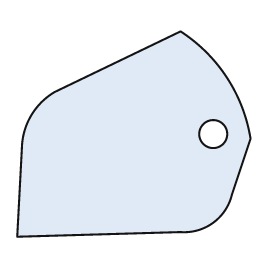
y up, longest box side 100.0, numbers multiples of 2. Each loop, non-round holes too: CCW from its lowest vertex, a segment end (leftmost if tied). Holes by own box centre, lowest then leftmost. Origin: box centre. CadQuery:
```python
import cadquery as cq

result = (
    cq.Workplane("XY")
    .moveTo(-50.0, -44.0)
    .lineTo(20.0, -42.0)
    .threePointArc((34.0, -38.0), (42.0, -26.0))
    .lineTo(50.0, -2.0)
    .threePointArc((40.0, 24.0), (20.0, 44.0))
    .lineTo(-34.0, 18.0)
    .threePointArc((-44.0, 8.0), (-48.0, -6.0))
    .close()
    .moveTo(34.0, 0.0)
    .circle(6.0)
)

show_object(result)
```